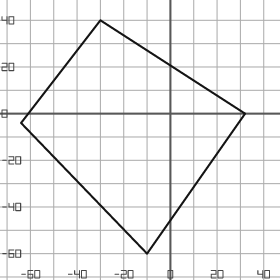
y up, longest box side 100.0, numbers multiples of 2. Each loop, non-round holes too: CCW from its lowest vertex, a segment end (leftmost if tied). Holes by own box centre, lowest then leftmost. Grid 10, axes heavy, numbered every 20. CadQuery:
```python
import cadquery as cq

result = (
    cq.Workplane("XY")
    .moveTo(-10.0, -60.0)
    .lineTo(32.0, 0.0)
    .lineTo(-30.0, 40.0)
    .lineTo(-64.0, -4.0)
    .close()
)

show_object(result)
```